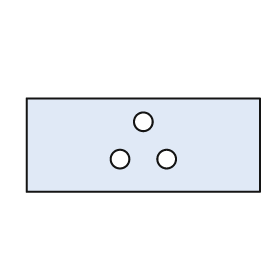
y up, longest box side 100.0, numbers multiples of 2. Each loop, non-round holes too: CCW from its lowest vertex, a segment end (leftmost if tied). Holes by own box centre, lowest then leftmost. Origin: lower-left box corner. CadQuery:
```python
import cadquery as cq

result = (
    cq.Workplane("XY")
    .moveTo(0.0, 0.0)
    .lineTo(100.0, 0.0)
    .lineTo(100.0, 40.0)
    .lineTo(0.0, 40.0)
    .close()
    .moveTo(40.0, 14.0)
    .circle(4.0)
    .moveTo(60.0, 14.0)
    .circle(4.0)
    .moveTo(50.0, 30.0)
    .circle(4.0)
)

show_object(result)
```